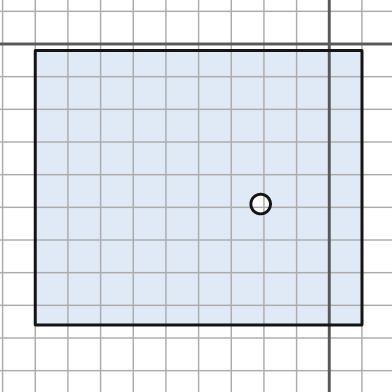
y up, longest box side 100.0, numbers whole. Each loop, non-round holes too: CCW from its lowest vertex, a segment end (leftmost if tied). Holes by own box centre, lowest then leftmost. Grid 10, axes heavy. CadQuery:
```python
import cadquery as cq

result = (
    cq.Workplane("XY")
    .moveTo(-90.0, -86.0)
    .lineTo(10.0, -86.0)
    .lineTo(10.0, -2.0)
    .lineTo(-90.0, -2.0)
    .close()
    .moveTo(-21.0, -49.0)
    .circle(3.0)
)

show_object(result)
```